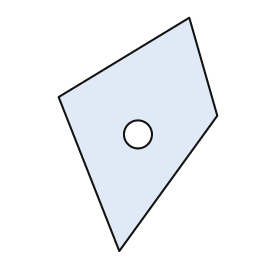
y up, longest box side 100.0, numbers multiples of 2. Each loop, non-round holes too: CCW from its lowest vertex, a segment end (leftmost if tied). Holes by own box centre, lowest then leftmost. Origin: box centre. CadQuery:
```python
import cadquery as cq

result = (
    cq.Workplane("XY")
    .moveTo(-8.0, -50.0)
    .lineTo(34.0, 8.0)
    .lineTo(22.0, 50.0)
    .lineTo(-34.0, 16.0)
    .close()
    .moveTo(0.0, 0.0)
    .circle(6.0)
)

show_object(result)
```